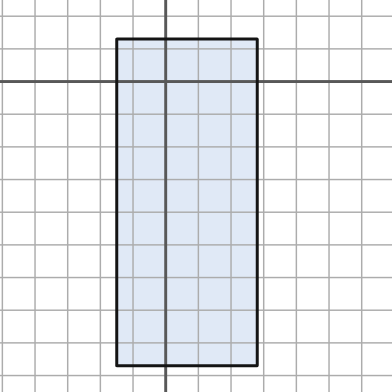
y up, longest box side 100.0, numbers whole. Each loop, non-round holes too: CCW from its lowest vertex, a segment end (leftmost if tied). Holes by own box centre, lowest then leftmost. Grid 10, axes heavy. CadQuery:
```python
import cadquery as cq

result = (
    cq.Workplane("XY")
    .moveTo(-15.0, -87.0)
    .lineTo(28.0, -87.0)
    .lineTo(28.0, 13.0)
    .lineTo(-15.0, 13.0)
    .close()
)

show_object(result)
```